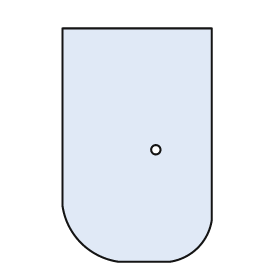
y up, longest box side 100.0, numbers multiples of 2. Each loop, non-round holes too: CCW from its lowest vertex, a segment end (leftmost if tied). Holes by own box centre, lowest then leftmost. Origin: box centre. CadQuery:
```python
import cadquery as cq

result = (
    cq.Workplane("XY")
    .moveTo(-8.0, -50.0)
    .lineTo(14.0, -50.0)
    .threePointArc((26.0, -44.0), (32.0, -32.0))
    .lineTo(32.0, 50.0)
    .lineTo(-32.0, 50.0)
    .lineTo(-32.0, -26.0)
    .threePointArc((-24.0, -42.0), (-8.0, -50.0))
    .close()
    .moveTo(8.0, -2.0)
    .circle(2.0)
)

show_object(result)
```